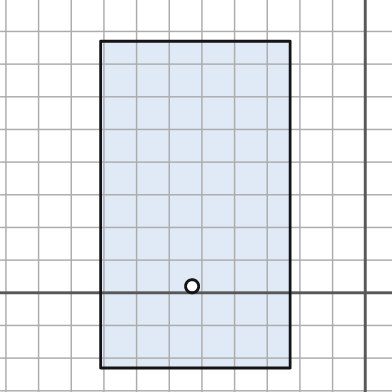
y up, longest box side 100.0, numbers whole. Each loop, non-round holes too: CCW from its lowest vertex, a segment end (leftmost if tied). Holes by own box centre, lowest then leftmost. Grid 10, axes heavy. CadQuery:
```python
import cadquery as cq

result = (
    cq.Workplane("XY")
    .moveTo(-81.0, -23.0)
    .lineTo(-23.0, -23.0)
    .lineTo(-23.0, 77.0)
    .lineTo(-81.0, 77.0)
    .close()
    .moveTo(-53.0, 2.0)
    .circle(2.0)
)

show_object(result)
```